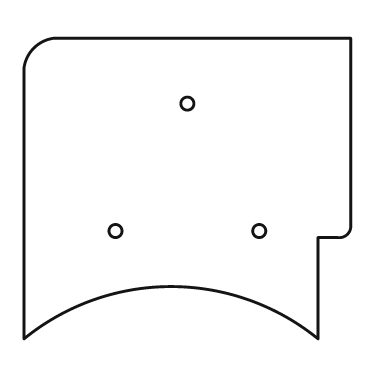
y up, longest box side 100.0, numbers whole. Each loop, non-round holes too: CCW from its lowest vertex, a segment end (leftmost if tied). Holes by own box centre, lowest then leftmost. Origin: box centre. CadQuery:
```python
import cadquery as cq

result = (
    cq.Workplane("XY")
    .moveTo(-50.0, -46.0)
    .threePointArc((-5.0, -30.0), (40.0, -46.0))
    .lineTo(40.0, -15.0)
    .lineTo(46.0, -15.0)
    .threePointArc((49.0, -14.0), (50.0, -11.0))
    .lineTo(50.0, 46.0)
    .lineTo(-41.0, 46.0)
    .threePointArc((-47.0, 43.0), (-50.0, 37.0))
    .close()
    .moveTo(-22.0, -13.0)
    .circle(2.0)
    .moveTo(22.0, -13.0)
    .circle(2.0)
    .moveTo(0.0, 26.0)
    .circle(2.0)
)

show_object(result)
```